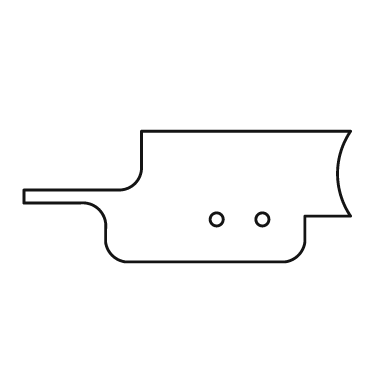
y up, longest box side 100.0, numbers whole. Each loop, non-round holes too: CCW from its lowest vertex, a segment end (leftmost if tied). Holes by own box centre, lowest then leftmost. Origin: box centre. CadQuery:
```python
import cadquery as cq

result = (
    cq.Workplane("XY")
    .moveTo(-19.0, -20.0)
    .lineTo(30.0, -20.0)
    .threePointArc((34.0, -18.0), (36.0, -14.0))
    .lineTo(36.0, -6.0)
    .lineTo(50.0, -6.0)
    .threePointArc((46.0, 7.0), (50.0, 20.0))
    .lineTo(-14.0, 20.0)
    .lineTo(-14.0, 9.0)
    .threePointArc((-16.0, 4.0), (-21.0, 2.0))
    .lineTo(-50.0, 2.0)
    .lineTo(-50.0, -2.0)
    .lineTo(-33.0, -2.0)
    .threePointArc((-27.0, -4.0), (-25.0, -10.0))
    .lineTo(-25.0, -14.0)
    .threePointArc((-23.0, -18.0), (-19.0, -20.0))
    .close()
    .moveTo(9.0, -7.0)
    .circle(2.0)
    .moveTo(23.0, -7.0)
    .circle(2.0)
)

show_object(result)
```